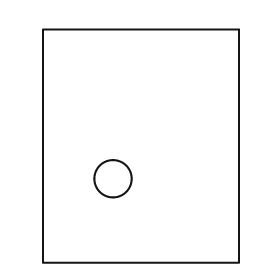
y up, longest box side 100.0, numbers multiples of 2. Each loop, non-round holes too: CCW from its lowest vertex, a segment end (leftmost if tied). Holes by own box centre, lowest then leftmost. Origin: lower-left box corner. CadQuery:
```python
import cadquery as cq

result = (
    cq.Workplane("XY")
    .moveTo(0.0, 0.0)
    .lineTo(84.0, 0.0)
    .lineTo(84.0, 100.0)
    .lineTo(0.0, 100.0)
    .close()
    .moveTo(30.0, 36.0)
    .circle(8.0)
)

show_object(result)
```